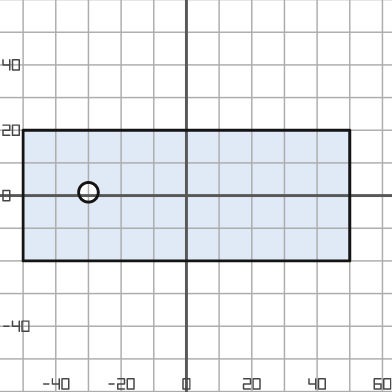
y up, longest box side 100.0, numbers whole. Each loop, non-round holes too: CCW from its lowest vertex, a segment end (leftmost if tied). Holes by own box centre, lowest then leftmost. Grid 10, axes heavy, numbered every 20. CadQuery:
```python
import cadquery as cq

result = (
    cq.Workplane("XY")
    .moveTo(-50.0, -20.0)
    .lineTo(50.0, -20.0)
    .lineTo(50.0, 20.0)
    .lineTo(-50.0, 20.0)
    .close()
    .moveTo(-30.0, 1.0)
    .circle(3.0)
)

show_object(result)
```